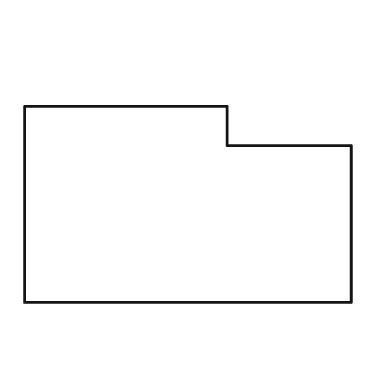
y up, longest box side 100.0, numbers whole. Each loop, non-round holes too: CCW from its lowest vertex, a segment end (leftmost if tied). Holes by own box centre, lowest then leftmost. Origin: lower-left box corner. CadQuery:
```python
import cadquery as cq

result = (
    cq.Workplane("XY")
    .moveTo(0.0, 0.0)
    .lineTo(100.0, 0.0)
    .lineTo(100.0, 48.0)
    .lineTo(62.0, 48.0)
    .lineTo(62.0, 60.0)
    .lineTo(0.0, 60.0)
    .close()
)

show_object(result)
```